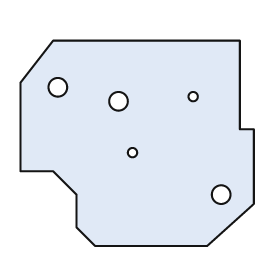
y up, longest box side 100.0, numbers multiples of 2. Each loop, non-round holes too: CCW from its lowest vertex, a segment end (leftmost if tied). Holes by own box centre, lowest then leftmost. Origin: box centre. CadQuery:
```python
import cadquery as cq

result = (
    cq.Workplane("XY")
    .moveTo(-18.0, -44.0)
    .lineTo(30.0, -44.0)
    .lineTo(50.0, -26.0)
    .lineTo(50.0, 6.0)
    .lineTo(44.0, 6.0)
    .lineTo(44.0, 44.0)
    .lineTo(-36.0, 44.0)
    .lineTo(-50.0, 26.0)
    .lineTo(-50.0, -12.0)
    .lineTo(-36.0, -12.0)
    .lineTo(-26.0, -22.0)
    .lineTo(-26.0, -36.0)
    .close()
    .moveTo(36.0, -22.0)
    .circle(4.0)
    .moveTo(-2.0, -4.0)
    .circle(2.0)
    .moveTo(-8.0, 18.0)
    .circle(4.0)
    .moveTo(24.0, 20.0)
    .circle(2.0)
    .moveTo(-34.0, 24.0)
    .circle(4.0)
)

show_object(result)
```